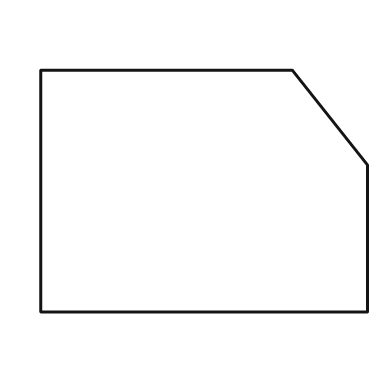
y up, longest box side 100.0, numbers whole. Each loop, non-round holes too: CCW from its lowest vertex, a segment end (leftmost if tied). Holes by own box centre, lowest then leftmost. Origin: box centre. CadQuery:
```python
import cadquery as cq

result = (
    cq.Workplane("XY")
    .moveTo(-50.0, -37.0)
    .lineTo(50.0, -37.0)
    .lineTo(50.0, 8.0)
    .lineTo(27.0, 37.0)
    .lineTo(-50.0, 37.0)
    .close()
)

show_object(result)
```